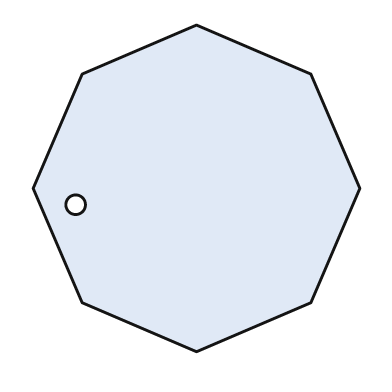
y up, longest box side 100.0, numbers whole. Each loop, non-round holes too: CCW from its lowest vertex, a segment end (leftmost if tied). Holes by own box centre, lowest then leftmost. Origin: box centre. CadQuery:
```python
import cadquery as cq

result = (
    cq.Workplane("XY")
    .moveTo(0.0, -50.0)
    .lineTo(35.0, -35.0)
    .lineTo(50.0, 0.0)
    .lineTo(35.0, 35.0)
    .lineTo(0.0, 50.0)
    .lineTo(-35.0, 35.0)
    .lineTo(-50.0, 0.0)
    .lineTo(-35.0, -35.0)
    .close()
    .moveTo(-37.0, -5.0)
    .circle(3.0)
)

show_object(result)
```